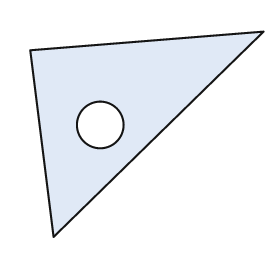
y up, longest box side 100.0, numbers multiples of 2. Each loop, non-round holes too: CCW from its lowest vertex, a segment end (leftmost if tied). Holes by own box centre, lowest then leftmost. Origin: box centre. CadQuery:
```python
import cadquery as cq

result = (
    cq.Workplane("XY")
    .moveTo(-40.0, -44.0)
    .lineTo(50.0, 44.0)
    .lineTo(-50.0, 36.0)
    .close()
    .moveTo(-20.0, 4.0)
    .circle(10.0)
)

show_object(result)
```